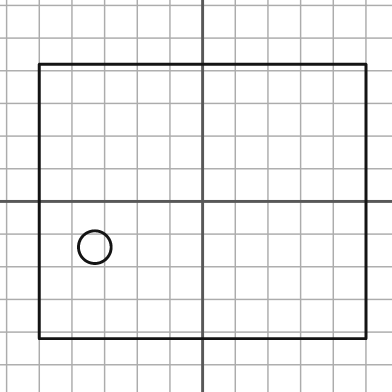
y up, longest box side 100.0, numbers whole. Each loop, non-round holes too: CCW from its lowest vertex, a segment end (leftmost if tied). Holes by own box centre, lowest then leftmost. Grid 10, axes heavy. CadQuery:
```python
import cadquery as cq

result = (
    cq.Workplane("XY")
    .moveTo(-50.0, -42.0)
    .lineTo(50.0, -42.0)
    .lineTo(50.0, 42.0)
    .lineTo(-50.0, 42.0)
    .close()
    .moveTo(-33.0, -14.0)
    .circle(5.0)
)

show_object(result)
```